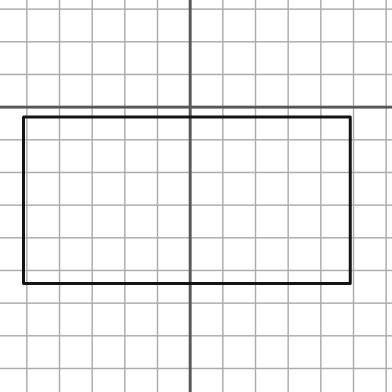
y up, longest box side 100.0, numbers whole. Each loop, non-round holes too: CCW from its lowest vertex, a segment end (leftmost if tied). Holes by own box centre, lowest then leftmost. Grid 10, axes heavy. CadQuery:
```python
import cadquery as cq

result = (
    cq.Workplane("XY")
    .moveTo(-51.0, -54.0)
    .lineTo(49.0, -54.0)
    .lineTo(49.0, -3.0)
    .lineTo(-51.0, -3.0)
    .close()
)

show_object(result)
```